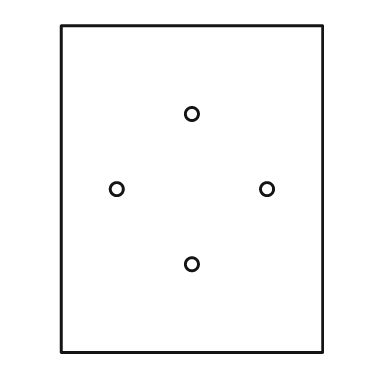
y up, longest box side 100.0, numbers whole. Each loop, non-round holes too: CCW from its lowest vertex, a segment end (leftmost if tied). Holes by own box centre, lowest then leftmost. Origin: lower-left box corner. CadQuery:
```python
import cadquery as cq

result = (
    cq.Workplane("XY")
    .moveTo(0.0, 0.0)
    .lineTo(80.0, 0.0)
    .lineTo(80.0, 100.0)
    .lineTo(0.0, 100.0)
    .close()
    .moveTo(40.0, 27.0)
    .circle(2.0)
    .moveTo(17.0, 50.0)
    .circle(2.0)
    .moveTo(63.0, 50.0)
    .circle(2.0)
    .moveTo(40.0, 73.0)
    .circle(2.0)
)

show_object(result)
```